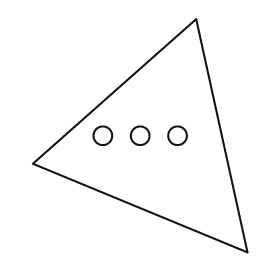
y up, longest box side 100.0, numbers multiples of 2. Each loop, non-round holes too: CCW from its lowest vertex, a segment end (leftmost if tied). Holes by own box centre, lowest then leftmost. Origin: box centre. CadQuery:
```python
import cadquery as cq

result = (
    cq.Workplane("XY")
    .moveTo(46.0, -50.0)
    .lineTo(24.0, 50.0)
    .lineTo(-46.0, -12.0)
    .close()
    .moveTo(-16.0, 0.0)
    .circle(4.0)
    .moveTo(0.0, 0.0)
    .circle(4.0)
    .moveTo(16.0, 0.0)
    .circle(4.0)
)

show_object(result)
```